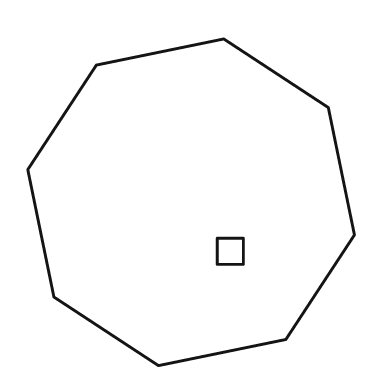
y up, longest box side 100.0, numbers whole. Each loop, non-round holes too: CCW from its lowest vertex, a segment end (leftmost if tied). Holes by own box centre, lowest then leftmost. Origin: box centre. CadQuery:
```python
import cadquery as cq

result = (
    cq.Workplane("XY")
    .moveTo(-10.0, -50.0)
    .lineTo(29.0, -42.0)
    .lineTo(50.0, -10.0)
    .lineTo(42.0, 29.0)
    .lineTo(10.0, 50.0)
    .lineTo(-29.0, 42.0)
    .lineTo(-50.0, 10.0)
    .lineTo(-42.0, -29.0)
    .close()
    .moveTo(8.0, -19.0)
    .lineTo(16.0, -19.0)
    .lineTo(16.0, -11.0)
    .lineTo(8.0, -11.0)
    .close()
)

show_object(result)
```